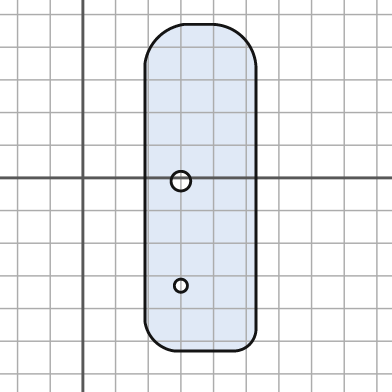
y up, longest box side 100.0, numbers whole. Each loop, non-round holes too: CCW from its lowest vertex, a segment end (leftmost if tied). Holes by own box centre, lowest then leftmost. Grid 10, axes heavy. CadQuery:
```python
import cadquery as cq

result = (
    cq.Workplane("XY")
    .moveTo(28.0, -53.0)
    .lineTo(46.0, -53.0)
    .threePointArc((51.0, -51.0), (53.0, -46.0))
    .lineTo(53.0, 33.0)
    .threePointArc((49.0, 43.0), (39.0, 47.0))
    .lineTo(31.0, 47.0)
    .threePointArc((23.0, 43.0), (19.0, 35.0))
    .lineTo(19.0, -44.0)
    .threePointArc((22.0, -50.0), (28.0, -53.0))
    .close()
    .moveTo(30.0, -33.0)
    .circle(2.0)
    .moveTo(30.0, -1.0)
    .circle(3.0)
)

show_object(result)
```